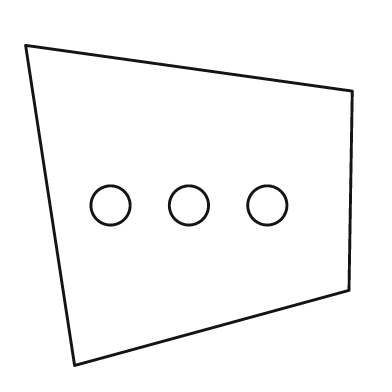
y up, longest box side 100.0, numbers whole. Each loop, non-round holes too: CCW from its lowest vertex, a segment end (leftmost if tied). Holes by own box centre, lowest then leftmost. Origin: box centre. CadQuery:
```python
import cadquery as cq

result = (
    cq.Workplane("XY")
    .moveTo(-35.0, -49.0)
    .lineTo(49.0, -26.0)
    .lineTo(50.0, 35.0)
    .lineTo(-50.0, 49.0)
    .close()
    .moveTo(-24.0, 0.0)
    .circle(6.0)
    .moveTo(0.0, 0.0)
    .circle(6.0)
    .moveTo(24.0, 0.0)
    .circle(6.0)
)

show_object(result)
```